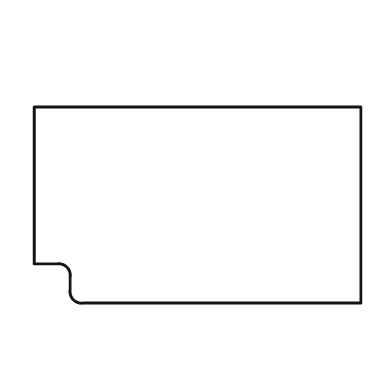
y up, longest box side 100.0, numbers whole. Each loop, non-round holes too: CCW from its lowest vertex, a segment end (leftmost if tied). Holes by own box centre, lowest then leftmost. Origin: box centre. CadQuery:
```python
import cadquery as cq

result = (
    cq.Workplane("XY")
    .moveTo(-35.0, -30.0)
    .lineTo(50.0, -30.0)
    .lineTo(50.0, 30.0)
    .lineTo(-50.0, 30.0)
    .lineTo(-50.0, -18.0)
    .lineTo(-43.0, -18.0)
    .threePointArc((-40.0, -19.0), (-39.0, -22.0))
    .lineTo(-39.0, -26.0)
    .threePointArc((-38.0, -29.0), (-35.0, -30.0))
    .close()
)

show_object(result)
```